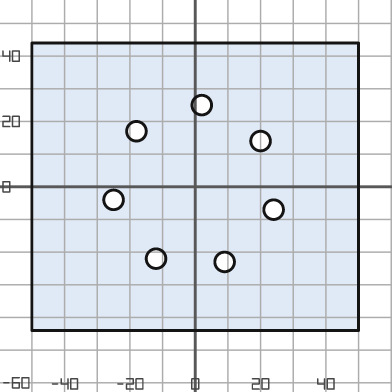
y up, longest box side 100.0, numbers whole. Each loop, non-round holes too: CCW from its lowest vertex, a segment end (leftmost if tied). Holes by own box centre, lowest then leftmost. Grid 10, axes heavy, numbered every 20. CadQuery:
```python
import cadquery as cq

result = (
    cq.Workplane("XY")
    .moveTo(-50.0, -44.0)
    .lineTo(50.0, -44.0)
    .lineTo(50.0, 44.0)
    .lineTo(-50.0, 44.0)
    .close()
    .moveTo(9.0, -23.0)
    .circle(3.0)
    .moveTo(-12.0, -22.0)
    .circle(3.0)
    .moveTo(24.0, -7.0)
    .circle(3.0)
    .moveTo(-25.0, -4.0)
    .circle(3.0)
    .moveTo(20.0, 14.0)
    .circle(3.0)
    .moveTo(-18.0, 17.0)
    .circle(3.0)
    .moveTo(2.0, 25.0)
    .circle(3.0)
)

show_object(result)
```